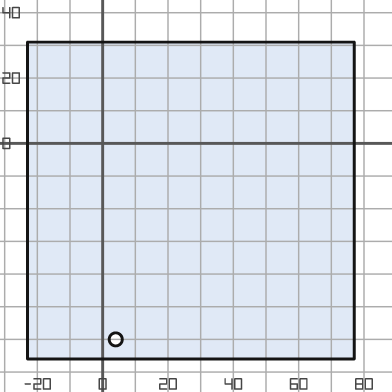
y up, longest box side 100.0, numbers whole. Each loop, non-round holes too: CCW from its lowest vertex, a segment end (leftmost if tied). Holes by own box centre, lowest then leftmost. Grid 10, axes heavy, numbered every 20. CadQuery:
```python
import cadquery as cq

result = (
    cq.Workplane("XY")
    .moveTo(-23.0, -66.0)
    .lineTo(77.0, -66.0)
    .lineTo(77.0, 31.0)
    .lineTo(-23.0, 31.0)
    .close()
    .moveTo(4.0, -60.0)
    .circle(2.0)
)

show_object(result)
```